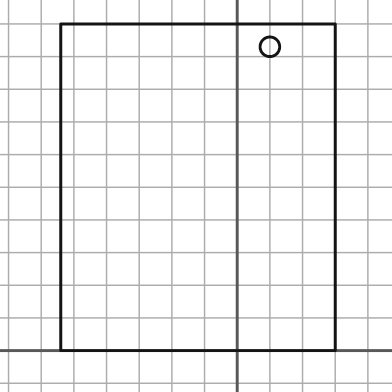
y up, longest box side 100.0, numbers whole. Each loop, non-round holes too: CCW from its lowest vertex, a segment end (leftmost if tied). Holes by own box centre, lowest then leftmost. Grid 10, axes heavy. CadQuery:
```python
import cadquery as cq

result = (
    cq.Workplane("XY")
    .moveTo(-54.0, 0.0)
    .lineTo(30.0, 0.0)
    .lineTo(30.0, 100.0)
    .lineTo(-54.0, 100.0)
    .close()
    .moveTo(10.0, 93.0)
    .circle(3.0)
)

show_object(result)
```